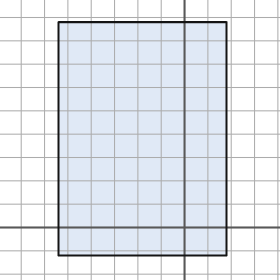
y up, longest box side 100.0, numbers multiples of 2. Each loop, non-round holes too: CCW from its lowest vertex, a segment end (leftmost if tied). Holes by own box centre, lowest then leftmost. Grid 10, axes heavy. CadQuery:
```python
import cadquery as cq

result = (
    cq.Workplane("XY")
    .moveTo(-54.0, -12.0)
    .lineTo(18.0, -12.0)
    .lineTo(18.0, 88.0)
    .lineTo(-54.0, 88.0)
    .close()
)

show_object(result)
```